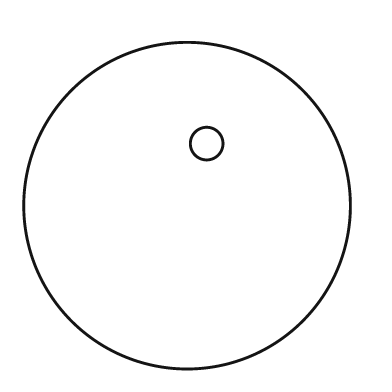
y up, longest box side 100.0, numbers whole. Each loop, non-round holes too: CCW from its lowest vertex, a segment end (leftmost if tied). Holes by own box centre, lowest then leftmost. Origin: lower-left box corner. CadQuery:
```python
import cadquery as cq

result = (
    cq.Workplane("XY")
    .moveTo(50.0, 50.0)
    .circle(50.0)
    .moveTo(56.0, 69.0)
    .circle(5.0)
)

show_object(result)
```